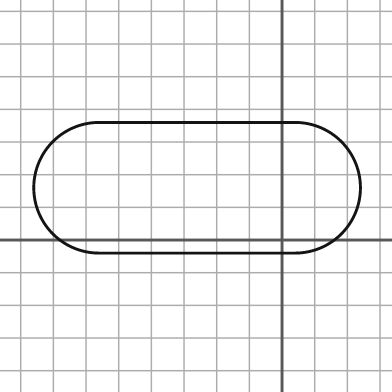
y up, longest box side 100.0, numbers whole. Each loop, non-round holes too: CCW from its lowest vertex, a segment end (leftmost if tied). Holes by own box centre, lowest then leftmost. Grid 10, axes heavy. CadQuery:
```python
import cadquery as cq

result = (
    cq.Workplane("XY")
    .moveTo(-56.0, -4.0)
    .lineTo(4.0, -4.0)
    .threePointArc((24.0, 16.0), (4.0, 36.0))
    .lineTo(-56.0, 36.0)
    .threePointArc((-76.0, 16.0), (-56.0, -4.0))
    .close()
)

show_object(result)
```